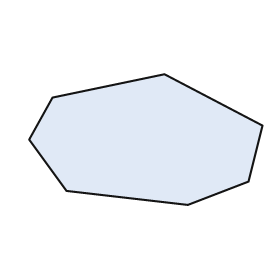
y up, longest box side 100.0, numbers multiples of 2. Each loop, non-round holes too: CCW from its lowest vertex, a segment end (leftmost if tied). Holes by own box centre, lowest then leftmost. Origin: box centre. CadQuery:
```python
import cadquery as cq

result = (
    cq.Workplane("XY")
    .moveTo(18.0, -28.0)
    .lineTo(44.0, -18.0)
    .lineTo(50.0, 6.0)
    .lineTo(8.0, 28.0)
    .lineTo(-40.0, 18.0)
    .lineTo(-50.0, 0.0)
    .lineTo(-34.0, -22.0)
    .close()
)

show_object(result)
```